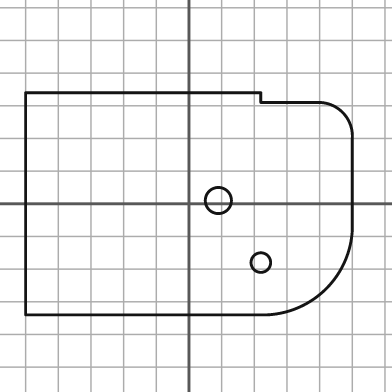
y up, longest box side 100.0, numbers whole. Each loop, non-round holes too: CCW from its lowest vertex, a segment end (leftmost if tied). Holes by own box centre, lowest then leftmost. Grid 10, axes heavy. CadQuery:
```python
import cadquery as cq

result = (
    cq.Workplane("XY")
    .moveTo(-50.0, -34.0)
    .lineTo(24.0, -34.0)
    .threePointArc((42.0, -26.0), (50.0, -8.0))
    .lineTo(50.0, 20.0)
    .threePointArc((47.0, 28.0), (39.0, 31.0))
    .lineTo(22.0, 31.0)
    .lineTo(22.0, 34.0)
    .lineTo(-50.0, 34.0)
    .close()
    .moveTo(22.0, -18.0)
    .circle(3.0)
    .moveTo(9.0, 1.0)
    .circle(4.0)
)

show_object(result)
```